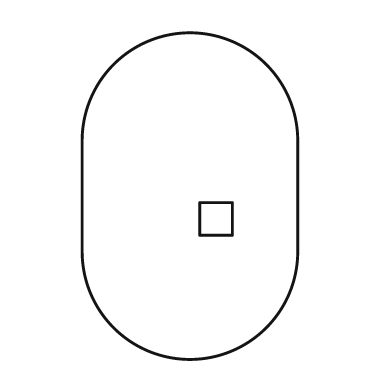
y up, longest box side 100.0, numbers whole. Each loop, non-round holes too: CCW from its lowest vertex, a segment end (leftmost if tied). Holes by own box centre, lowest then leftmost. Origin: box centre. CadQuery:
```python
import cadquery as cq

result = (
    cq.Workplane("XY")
    .moveTo(-33.0, -17.0)
    .threePointArc((0.0, -50.0), (33.0, -17.0))
    .lineTo(33.0, 17.0)
    .threePointArc((0.0, 50.0), (-33.0, 17.0))
    .close()
    .moveTo(3.0, -12.0)
    .lineTo(13.0, -12.0)
    .lineTo(13.0, -2.0)
    .lineTo(3.0, -2.0)
    .close()
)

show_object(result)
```